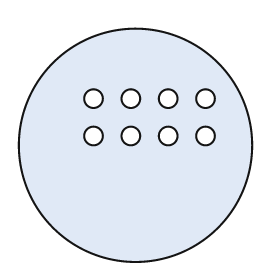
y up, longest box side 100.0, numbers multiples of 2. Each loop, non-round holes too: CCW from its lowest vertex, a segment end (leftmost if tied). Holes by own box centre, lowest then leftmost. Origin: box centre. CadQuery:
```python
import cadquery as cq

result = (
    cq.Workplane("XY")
    .moveTo(0.0, 0.0)
    .circle(50.0)
    .moveTo(-18.0, 4.0)
    .circle(4.0)
    .moveTo(-2.0, 4.0)
    .circle(4.0)
    .moveTo(14.0, 4.0)
    .circle(4.0)
    .moveTo(30.0, 4.0)
    .circle(4.0)
    .moveTo(-18.0, 20.0)
    .circle(4.0)
    .moveTo(-2.0, 20.0)
    .circle(4.0)
    .moveTo(14.0, 20.0)
    .circle(4.0)
    .moveTo(30.0, 20.0)
    .circle(4.0)
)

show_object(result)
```